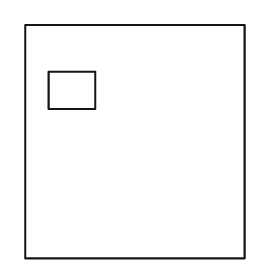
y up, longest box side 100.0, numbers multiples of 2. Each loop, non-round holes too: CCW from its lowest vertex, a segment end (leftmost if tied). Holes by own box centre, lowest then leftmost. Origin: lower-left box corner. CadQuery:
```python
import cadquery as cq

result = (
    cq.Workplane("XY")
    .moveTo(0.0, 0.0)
    .lineTo(94.0, 0.0)
    .lineTo(94.0, 100.0)
    .lineTo(0.0, 100.0)
    .close()
    .moveTo(10.0, 64.0)
    .lineTo(30.0, 64.0)
    .lineTo(30.0, 80.0)
    .lineTo(10.0, 80.0)
    .close()
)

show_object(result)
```